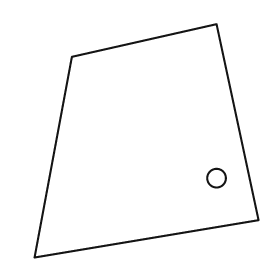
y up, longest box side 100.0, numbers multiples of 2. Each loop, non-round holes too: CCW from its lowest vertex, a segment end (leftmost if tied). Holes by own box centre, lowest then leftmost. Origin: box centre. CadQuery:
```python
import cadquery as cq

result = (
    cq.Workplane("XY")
    .moveTo(-48.0, -50.0)
    .lineTo(48.0, -34.0)
    .lineTo(30.0, 50.0)
    .lineTo(-32.0, 36.0)
    .close()
    .moveTo(30.0, -16.0)
    .circle(4.0)
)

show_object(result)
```